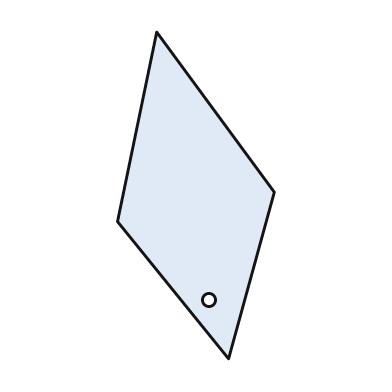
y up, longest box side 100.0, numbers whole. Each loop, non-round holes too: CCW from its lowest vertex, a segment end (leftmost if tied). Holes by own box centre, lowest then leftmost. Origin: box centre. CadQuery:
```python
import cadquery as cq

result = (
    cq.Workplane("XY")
    .moveTo(10.0, -50.0)
    .lineTo(24.0, 1.0)
    .lineTo(-12.0, 50.0)
    .lineTo(-24.0, -8.0)
    .close()
    .moveTo(4.0, -32.0)
    .circle(2.0)
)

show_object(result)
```